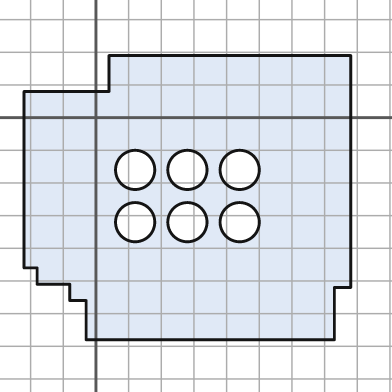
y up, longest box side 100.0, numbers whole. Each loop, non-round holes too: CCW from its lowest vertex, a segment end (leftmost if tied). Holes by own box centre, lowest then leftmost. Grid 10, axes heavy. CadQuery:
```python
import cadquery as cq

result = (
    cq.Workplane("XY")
    .moveTo(-3.0, -68.0)
    .lineTo(73.0, -68.0)
    .lineTo(73.0, -52.0)
    .lineTo(78.0, -52.0)
    .lineTo(78.0, 19.0)
    .lineTo(4.0, 19.0)
    .lineTo(4.0, 8.0)
    .lineTo(-22.0, 8.0)
    .lineTo(-22.0, -46.0)
    .lineTo(-18.0, -46.0)
    .lineTo(-18.0, -51.0)
    .lineTo(-8.0, -51.0)
    .lineTo(-8.0, -56.0)
    .lineTo(-3.0, -56.0)
    .close()
    .moveTo(12.0, -32.0)
    .circle(6.0)
    .moveTo(28.0, -32.0)
    .circle(6.0)
    .moveTo(44.0, -32.0)
    .circle(6.0)
    .moveTo(12.0, -16.0)
    .circle(6.0)
    .moveTo(28.0, -16.0)
    .circle(6.0)
    .moveTo(44.0, -16.0)
    .circle(6.0)
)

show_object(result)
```